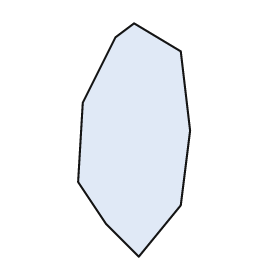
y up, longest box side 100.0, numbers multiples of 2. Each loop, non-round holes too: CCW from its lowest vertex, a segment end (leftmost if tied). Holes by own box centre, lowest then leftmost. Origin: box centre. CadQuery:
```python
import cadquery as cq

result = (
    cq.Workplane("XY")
    .moveTo(2.0, -50.0)
    .lineTo(20.0, -28.0)
    .lineTo(24.0, 4.0)
    .lineTo(20.0, 38.0)
    .lineTo(0.0, 50.0)
    .lineTo(-8.0, 44.0)
    .lineTo(-22.0, 16.0)
    .lineTo(-24.0, -18.0)
    .lineTo(-12.0, -36.0)
    .close()
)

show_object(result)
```